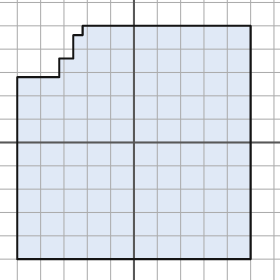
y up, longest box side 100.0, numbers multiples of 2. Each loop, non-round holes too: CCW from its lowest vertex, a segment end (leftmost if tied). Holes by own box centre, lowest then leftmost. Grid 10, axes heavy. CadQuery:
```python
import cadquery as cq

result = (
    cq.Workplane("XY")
    .moveTo(-50.0, -50.0)
    .lineTo(50.0, -50.0)
    .lineTo(50.0, 50.0)
    .lineTo(-22.0, 50.0)
    .lineTo(-22.0, 46.0)
    .lineTo(-26.0, 46.0)
    .lineTo(-26.0, 36.0)
    .lineTo(-32.0, 36.0)
    .lineTo(-32.0, 28.0)
    .lineTo(-50.0, 28.0)
    .close()
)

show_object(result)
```